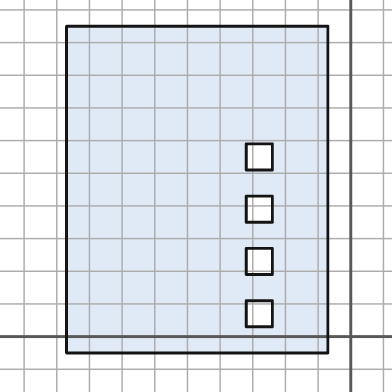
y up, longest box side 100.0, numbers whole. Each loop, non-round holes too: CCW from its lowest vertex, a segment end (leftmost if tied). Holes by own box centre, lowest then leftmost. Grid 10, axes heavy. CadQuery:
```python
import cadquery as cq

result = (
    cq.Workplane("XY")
    .moveTo(-87.0, -5.0)
    .lineTo(-7.0, -5.0)
    .lineTo(-7.0, 95.0)
    .lineTo(-87.0, 95.0)
    .close()
    .moveTo(-32.0, 3.0)
    .lineTo(-24.0, 3.0)
    .lineTo(-24.0, 11.0)
    .lineTo(-32.0, 11.0)
    .close()
    .moveTo(-32.0, 19.0)
    .lineTo(-24.0, 19.0)
    .lineTo(-24.0, 27.0)
    .lineTo(-32.0, 27.0)
    .close()
    .moveTo(-32.0, 35.0)
    .lineTo(-24.0, 35.0)
    .lineTo(-24.0, 43.0)
    .lineTo(-32.0, 43.0)
    .close()
    .moveTo(-32.0, 51.0)
    .lineTo(-24.0, 51.0)
    .lineTo(-24.0, 59.0)
    .lineTo(-32.0, 59.0)
    .close()
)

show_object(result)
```